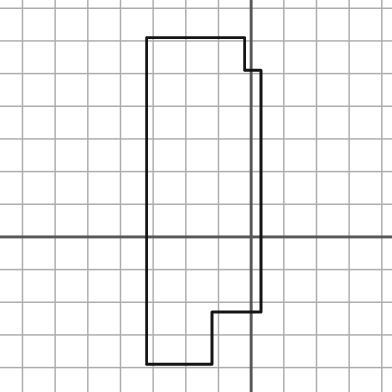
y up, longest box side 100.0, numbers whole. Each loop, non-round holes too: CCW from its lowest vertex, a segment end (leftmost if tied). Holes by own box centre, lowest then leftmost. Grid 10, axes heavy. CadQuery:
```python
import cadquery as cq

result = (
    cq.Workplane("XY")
    .moveTo(-32.0, -39.0)
    .lineTo(-12.0, -39.0)
    .lineTo(-12.0, -23.0)
    .lineTo(3.0, -23.0)
    .lineTo(3.0, 51.0)
    .lineTo(-2.0, 51.0)
    .lineTo(-2.0, 61.0)
    .lineTo(-32.0, 61.0)
    .close()
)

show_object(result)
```